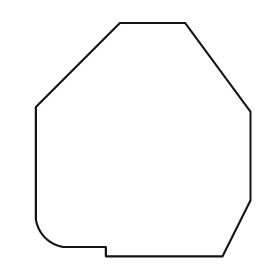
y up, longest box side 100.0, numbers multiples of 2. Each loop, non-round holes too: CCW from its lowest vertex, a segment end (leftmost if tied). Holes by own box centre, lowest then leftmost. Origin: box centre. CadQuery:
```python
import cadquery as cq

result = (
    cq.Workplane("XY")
    .moveTo(-16.0, -50.0)
    .lineTo(34.0, -50.0)
    .lineTo(46.0, -26.0)
    .lineTo(46.0, 12.0)
    .lineTo(18.0, 50.0)
    .lineTo(-10.0, 50.0)
    .lineTo(-46.0, 14.0)
    .lineTo(-46.0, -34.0)
    .threePointArc((-42.0, -42.0), (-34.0, -46.0))
    .lineTo(-16.0, -46.0)
    .close()
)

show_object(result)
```